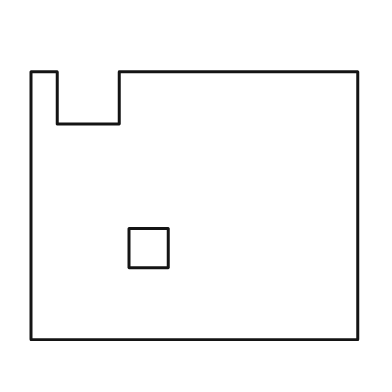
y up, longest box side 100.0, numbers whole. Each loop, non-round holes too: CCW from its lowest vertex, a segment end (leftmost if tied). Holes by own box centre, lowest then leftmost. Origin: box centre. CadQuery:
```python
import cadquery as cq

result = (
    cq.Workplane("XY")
    .moveTo(-50.0, -41.0)
    .lineTo(50.0, -41.0)
    .lineTo(50.0, 41.0)
    .lineTo(-23.0, 41.0)
    .lineTo(-23.0, 25.0)
    .lineTo(-42.0, 25.0)
    .lineTo(-42.0, 41.0)
    .lineTo(-50.0, 41.0)
    .close()
    .moveTo(-20.0, -19.0)
    .lineTo(-8.0, -19.0)
    .lineTo(-8.0, -7.0)
    .lineTo(-20.0, -7.0)
    .close()
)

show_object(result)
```